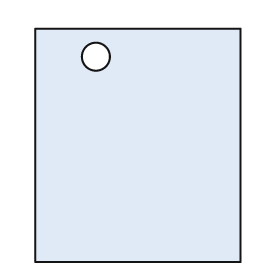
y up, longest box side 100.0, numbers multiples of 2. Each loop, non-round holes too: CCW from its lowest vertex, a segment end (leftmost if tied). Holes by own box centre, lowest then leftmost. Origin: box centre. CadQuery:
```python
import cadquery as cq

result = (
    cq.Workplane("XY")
    .moveTo(-44.0, -50.0)
    .lineTo(44.0, -50.0)
    .lineTo(44.0, 50.0)
    .lineTo(-44.0, 50.0)
    .close()
    .moveTo(-18.0, 38.0)
    .circle(6.0)
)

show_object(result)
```